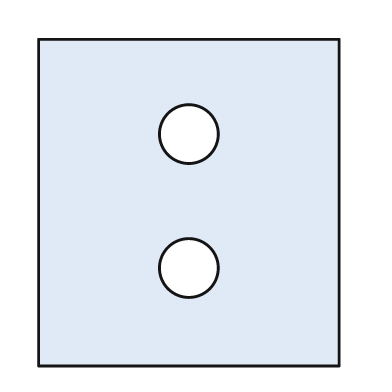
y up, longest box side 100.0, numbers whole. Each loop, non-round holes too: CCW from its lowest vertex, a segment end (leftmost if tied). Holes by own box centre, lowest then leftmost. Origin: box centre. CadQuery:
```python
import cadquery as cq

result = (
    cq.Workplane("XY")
    .moveTo(-46.0, -50.0)
    .lineTo(46.0, -50.0)
    .lineTo(46.0, 50.0)
    .lineTo(-46.0, 50.0)
    .close()
    .moveTo(0.0, -20.0)
    .circle(9.0)
    .moveTo(0.0, 21.0)
    .circle(9.0)
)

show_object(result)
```